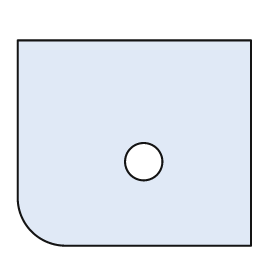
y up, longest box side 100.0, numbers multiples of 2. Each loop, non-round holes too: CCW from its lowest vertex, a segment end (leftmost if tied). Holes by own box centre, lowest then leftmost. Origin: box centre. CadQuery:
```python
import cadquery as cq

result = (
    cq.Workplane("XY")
    .moveTo(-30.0, -44.0)
    .lineTo(50.0, -44.0)
    .lineTo(50.0, 44.0)
    .lineTo(-50.0, 44.0)
    .lineTo(-50.0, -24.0)
    .threePointArc((-44.0, -38.0), (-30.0, -44.0))
    .close()
    .moveTo(4.0, -8.0)
    .circle(8.0)
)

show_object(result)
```